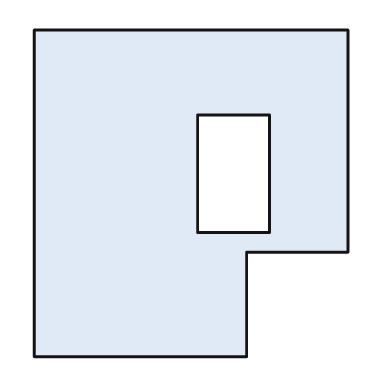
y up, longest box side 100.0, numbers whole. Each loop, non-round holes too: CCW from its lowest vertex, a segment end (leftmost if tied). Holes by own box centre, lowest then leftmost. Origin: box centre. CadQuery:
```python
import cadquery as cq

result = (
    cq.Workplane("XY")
    .moveTo(-48.0, -50.0)
    .lineTo(17.0, -50.0)
    .lineTo(17.0, -18.0)
    .lineTo(48.0, -18.0)
    .lineTo(48.0, 50.0)
    .lineTo(-48.0, 50.0)
    .close()
    .moveTo(2.0, -12.0)
    .lineTo(24.0, -12.0)
    .lineTo(24.0, 24.0)
    .lineTo(2.0, 24.0)
    .close()
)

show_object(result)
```